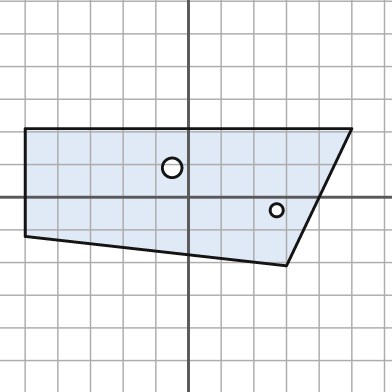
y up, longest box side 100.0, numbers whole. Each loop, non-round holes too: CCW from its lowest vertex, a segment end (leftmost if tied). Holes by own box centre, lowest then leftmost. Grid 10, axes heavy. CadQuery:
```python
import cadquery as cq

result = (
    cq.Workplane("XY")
    .moveTo(30.0, -21.0)
    .lineTo(50.0, 21.0)
    .lineTo(-50.0, 21.0)
    .lineTo(-50.0, -12.0)
    .close()
    .moveTo(27.0, -4.0)
    .circle(2.0)
    .moveTo(-5.0, 9.0)
    .circle(3.0)
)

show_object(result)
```